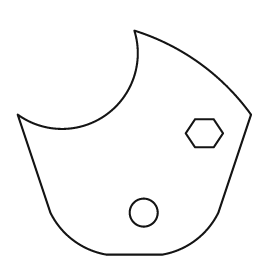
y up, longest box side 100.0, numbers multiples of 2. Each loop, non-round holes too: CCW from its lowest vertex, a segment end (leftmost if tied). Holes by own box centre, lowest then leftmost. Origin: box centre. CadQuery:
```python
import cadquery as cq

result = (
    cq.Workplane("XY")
    .moveTo(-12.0, -48.0)
    .lineTo(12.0, -48.0)
    .threePointArc((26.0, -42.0), (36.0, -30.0))
    .lineTo(50.0, 12.0)
    .threePointArc((28.0, 34.0), (0.0, 48.0))
    .threePointArc((-12.0, 12.0), (-50.0, 12.0))
    .lineTo(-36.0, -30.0)
    .threePointArc((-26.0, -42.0), (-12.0, -48.0))
    .close()
    .moveTo(4.0, -30.0)
    .circle(6.0)
    .moveTo(26.0, -2.0)
    .lineTo(34.0, -2.0)
    .lineTo(38.0, 4.0)
    .lineTo(34.0, 10.0)
    .lineTo(26.0, 10.0)
    .lineTo(22.0, 4.0)
    .close()
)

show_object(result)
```